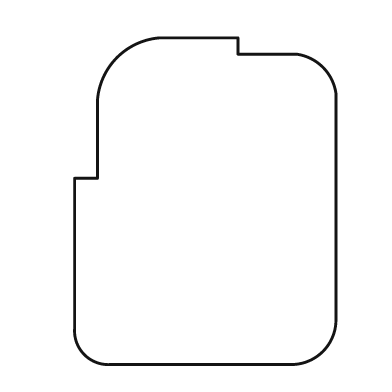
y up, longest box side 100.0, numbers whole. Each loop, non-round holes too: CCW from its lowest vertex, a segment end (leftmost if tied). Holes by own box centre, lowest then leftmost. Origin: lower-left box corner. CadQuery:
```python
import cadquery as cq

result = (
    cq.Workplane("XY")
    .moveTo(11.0, 0.0)
    .lineTo(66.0, 0.0)
    .threePointArc((76.0, 4.0), (80.0, 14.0))
    .lineTo(80.0, 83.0)
    .threePointArc((76.0, 91.0), (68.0, 95.0))
    .lineTo(50.0, 95.0)
    .lineTo(50.0, 100.0)
    .lineTo(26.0, 100.0)
    .threePointArc((13.0, 94.0), (7.0, 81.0))
    .lineTo(7.0, 57.0)
    .lineTo(0.0, 57.0)
    .lineTo(0.0, 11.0)
    .threePointArc((3.0, 3.0), (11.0, 0.0))
    .close()
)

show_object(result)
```